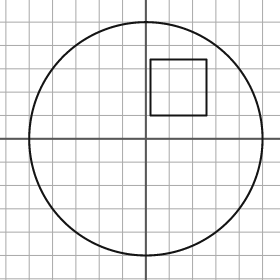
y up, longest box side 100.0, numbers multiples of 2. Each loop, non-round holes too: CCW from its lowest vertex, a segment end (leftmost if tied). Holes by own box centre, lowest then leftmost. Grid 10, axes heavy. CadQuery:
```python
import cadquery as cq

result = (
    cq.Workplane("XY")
    .moveTo(0.0, 0.0)
    .circle(50.0)
    .moveTo(2.0, 10.0)
    .lineTo(26.0, 10.0)
    .lineTo(26.0, 34.0)
    .lineTo(2.0, 34.0)
    .close()
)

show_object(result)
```